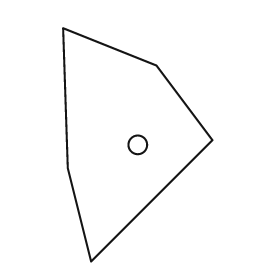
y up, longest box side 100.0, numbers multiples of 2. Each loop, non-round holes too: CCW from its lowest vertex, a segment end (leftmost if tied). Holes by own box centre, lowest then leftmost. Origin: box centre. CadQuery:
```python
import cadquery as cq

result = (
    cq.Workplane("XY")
    .moveTo(-20.0, -50.0)
    .lineTo(32.0, 2.0)
    .lineTo(8.0, 34.0)
    .lineTo(-32.0, 50.0)
    .lineTo(-30.0, -10.0)
    .close()
    .moveTo(0.0, 0.0)
    .circle(4.0)
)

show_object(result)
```